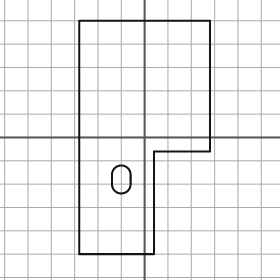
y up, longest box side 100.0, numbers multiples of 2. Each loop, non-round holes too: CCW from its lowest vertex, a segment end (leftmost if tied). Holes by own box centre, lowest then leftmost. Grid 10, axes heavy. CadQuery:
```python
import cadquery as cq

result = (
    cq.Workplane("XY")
    .moveTo(-28.0, -50.0)
    .lineTo(4.0, -50.0)
    .lineTo(4.0, -6.0)
    .lineTo(28.0, -6.0)
    .lineTo(28.0, 50.0)
    .lineTo(-28.0, 50.0)
    .close()
    .moveTo(-14.0, -20.0)
    .threePointArc((-10.0, -24.0), (-6.0, -20.0))
    .lineTo(-6.0, -16.0)
    .threePointArc((-10.0, -12.0), (-14.0, -16.0))
    .close()
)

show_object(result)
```